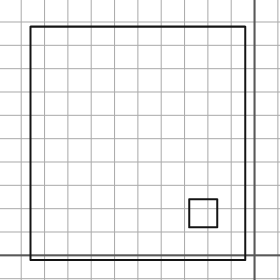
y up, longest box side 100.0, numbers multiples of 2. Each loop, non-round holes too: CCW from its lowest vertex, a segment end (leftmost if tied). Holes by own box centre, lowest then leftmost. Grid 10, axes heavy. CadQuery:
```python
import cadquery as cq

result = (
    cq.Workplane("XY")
    .moveTo(-96.0, -2.0)
    .lineTo(-4.0, -2.0)
    .lineTo(-4.0, 98.0)
    .lineTo(-96.0, 98.0)
    .close()
    .moveTo(-28.0, 12.0)
    .lineTo(-16.0, 12.0)
    .lineTo(-16.0, 24.0)
    .lineTo(-28.0, 24.0)
    .close()
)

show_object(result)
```